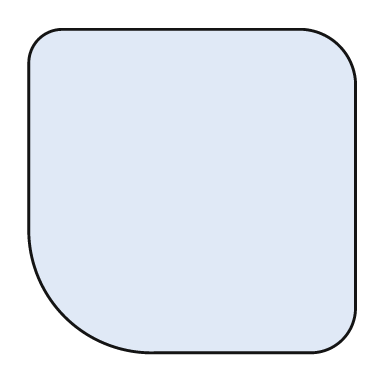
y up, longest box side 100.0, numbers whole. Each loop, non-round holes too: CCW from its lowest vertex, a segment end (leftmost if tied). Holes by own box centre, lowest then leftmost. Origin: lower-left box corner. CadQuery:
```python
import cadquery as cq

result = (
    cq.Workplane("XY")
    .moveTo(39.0, 0.0)
    .lineTo(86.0, 0.0)
    .threePointArc((96.0, 4.0), (100.0, 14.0))
    .lineTo(100.0, 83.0)
    .threePointArc((95.0, 94.0), (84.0, 99.0))
    .lineTo(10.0, 99.0)
    .threePointArc((3.0, 96.0), (0.0, 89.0))
    .lineTo(0.0, 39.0)
    .threePointArc((11.0, 11.0), (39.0, 0.0))
    .close()
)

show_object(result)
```